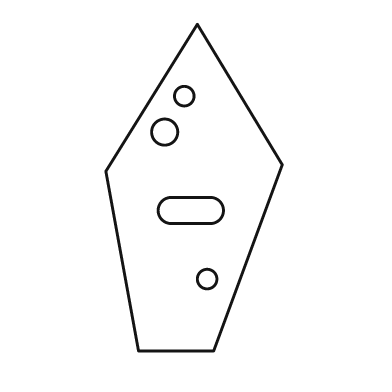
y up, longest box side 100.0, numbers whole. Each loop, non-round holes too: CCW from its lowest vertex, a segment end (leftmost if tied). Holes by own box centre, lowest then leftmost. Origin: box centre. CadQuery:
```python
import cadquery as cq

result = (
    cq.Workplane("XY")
    .moveTo(-17.0, -50.0)
    .lineTo(6.0, -50.0)
    .lineTo(27.0, 7.0)
    .lineTo(1.0, 50.0)
    .lineTo(-27.0, 5.0)
    .close()
    .moveTo(4.0, -28.0)
    .circle(3.0)
    .moveTo(-7.0, -11.0)
    .lineTo(5.0, -11.0)
    .threePointArc((9.0, -7.0), (5.0, -3.0))
    .lineTo(-7.0, -3.0)
    .threePointArc((-11.0, -7.0), (-7.0, -11.0))
    .close()
    .moveTo(-9.0, 17.0)
    .circle(4.0)
    .moveTo(-3.0, 28.0)
    .circle(3.0)
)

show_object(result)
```